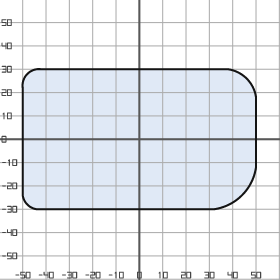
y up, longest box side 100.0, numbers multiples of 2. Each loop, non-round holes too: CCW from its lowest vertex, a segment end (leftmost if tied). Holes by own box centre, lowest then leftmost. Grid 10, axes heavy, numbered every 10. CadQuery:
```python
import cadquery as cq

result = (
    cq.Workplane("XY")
    .moveTo(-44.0, -30.0)
    .lineTo(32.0, -30.0)
    .threePointArc((44.0, -24.0), (50.0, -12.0))
    .lineTo(50.0, 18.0)
    .threePointArc((46.0, 26.0), (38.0, 30.0))
    .lineTo(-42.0, 30.0)
    .threePointArc((-48.0, 28.0), (-50.0, 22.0))
    .lineTo(-50.0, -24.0)
    .threePointArc((-48.0, -28.0), (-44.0, -30.0))
    .close()
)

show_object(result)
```